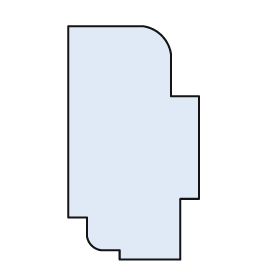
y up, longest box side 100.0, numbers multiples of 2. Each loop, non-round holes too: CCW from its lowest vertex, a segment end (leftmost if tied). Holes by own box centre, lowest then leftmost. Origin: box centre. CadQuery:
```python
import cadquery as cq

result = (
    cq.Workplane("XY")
    .moveTo(-6.0, -50.0)
    .lineTo(20.0, -50.0)
    .lineTo(20.0, -24.0)
    .lineTo(28.0, -24.0)
    .lineTo(28.0, 20.0)
    .lineTo(16.0, 20.0)
    .lineTo(16.0, 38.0)
    .threePointArc((12.0, 46.0), (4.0, 50.0))
    .lineTo(-28.0, 50.0)
    .lineTo(-28.0, -32.0)
    .lineTo(-20.0, -32.0)
    .lineTo(-20.0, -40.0)
    .threePointArc((-18.0, -44.0), (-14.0, -46.0))
    .lineTo(-6.0, -46.0)
    .close()
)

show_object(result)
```